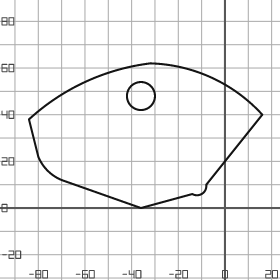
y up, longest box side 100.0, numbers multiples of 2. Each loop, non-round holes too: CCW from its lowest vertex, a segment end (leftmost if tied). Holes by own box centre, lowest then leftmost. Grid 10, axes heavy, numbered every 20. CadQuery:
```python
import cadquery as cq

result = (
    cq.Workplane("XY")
    .moveTo(-36.0, 0.0)
    .lineTo(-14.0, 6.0)
    .threePointArc((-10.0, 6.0), (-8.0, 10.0))
    .lineTo(16.0, 40.0)
    .threePointArc((-6.0, 56.0), (-32.0, 62.0))
    .threePointArc((-60.0, 54.0), (-84.0, 38.0))
    .lineTo(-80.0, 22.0)
    .threePointArc((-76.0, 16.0), (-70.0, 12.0))
    .close()
    .moveTo(-36.0, 48.0)
    .circle(6.0)
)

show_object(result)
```